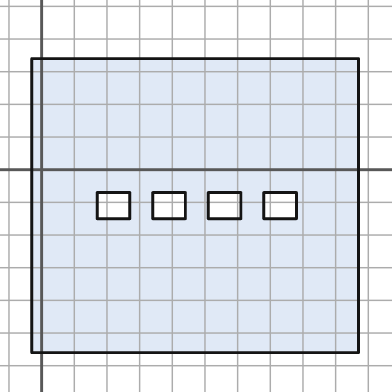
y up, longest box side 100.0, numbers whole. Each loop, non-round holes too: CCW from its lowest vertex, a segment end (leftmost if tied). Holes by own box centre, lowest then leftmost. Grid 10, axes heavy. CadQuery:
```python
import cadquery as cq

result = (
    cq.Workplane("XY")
    .moveTo(-3.0, -56.0)
    .lineTo(97.0, -56.0)
    .lineTo(97.0, 34.0)
    .lineTo(-3.0, 34.0)
    .close()
    .moveTo(17.0, -15.0)
    .lineTo(27.0, -15.0)
    .lineTo(27.0, -7.0)
    .lineTo(17.0, -7.0)
    .close()
    .moveTo(34.0, -15.0)
    .lineTo(44.0, -15.0)
    .lineTo(44.0, -7.0)
    .lineTo(34.0, -7.0)
    .close()
    .moveTo(51.0, -15.0)
    .lineTo(61.0, -15.0)
    .lineTo(61.0, -7.0)
    .lineTo(51.0, -7.0)
    .close()
    .moveTo(68.0, -15.0)
    .lineTo(78.0, -15.0)
    .lineTo(78.0, -7.0)
    .lineTo(68.0, -7.0)
    .close()
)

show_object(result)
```